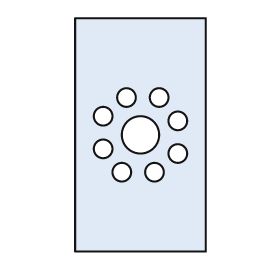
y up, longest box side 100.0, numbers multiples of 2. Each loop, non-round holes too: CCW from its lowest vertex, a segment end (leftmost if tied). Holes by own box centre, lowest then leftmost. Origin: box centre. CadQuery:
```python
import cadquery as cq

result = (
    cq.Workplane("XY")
    .moveTo(-28.0, -50.0)
    .lineTo(28.0, -50.0)
    .lineTo(28.0, 50.0)
    .lineTo(-28.0, 50.0)
    .close()
    .moveTo(-8.0, -16.0)
    .circle(4.0)
    .moveTo(6.0, -16.0)
    .circle(4.0)
    .moveTo(16.0, -8.0)
    .circle(4.0)
    .moveTo(-16.0, -6.0)
    .circle(4.0)
    .moveTo(0.0, 0.0)
    .circle(8.0)
    .moveTo(16.0, 6.0)
    .circle(4.0)
    .moveTo(-16.0, 8.0)
    .circle(4.0)
    .moveTo(-6.0, 16.0)
    .circle(4.0)
    .moveTo(8.0, 16.0)
    .circle(4.0)
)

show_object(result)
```